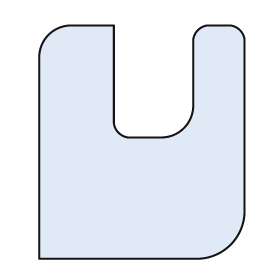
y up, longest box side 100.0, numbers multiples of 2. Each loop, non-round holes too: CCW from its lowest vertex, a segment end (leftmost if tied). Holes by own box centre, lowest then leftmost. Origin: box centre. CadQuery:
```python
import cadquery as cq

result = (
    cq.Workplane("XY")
    .moveTo(-44.0, -50.0)
    .lineTo(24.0, -50.0)
    .threePointArc((38.0, -44.0), (44.0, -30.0))
    .lineTo(44.0, 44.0)
    .threePointArc((42.0, 48.0), (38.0, 50.0))
    .lineTo(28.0, 50.0)
    .threePointArc((24.0, 48.0), (22.0, 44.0))
    .lineTo(22.0, 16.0)
    .threePointArc((18.0, 6.0), (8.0, 2.0))
    .lineTo(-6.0, 2.0)
    .threePointArc((-10.0, 4.0), (-12.0, 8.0))
    .lineTo(-12.0, 50.0)
    .lineTo(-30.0, 50.0)
    .threePointArc((-40.0, 46.0), (-44.0, 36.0))
    .close()
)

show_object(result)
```